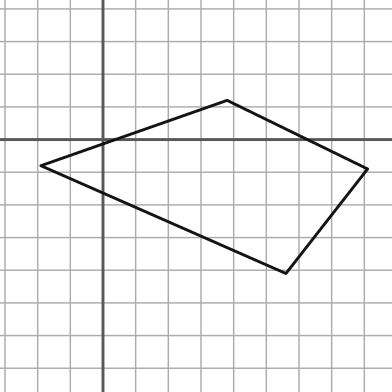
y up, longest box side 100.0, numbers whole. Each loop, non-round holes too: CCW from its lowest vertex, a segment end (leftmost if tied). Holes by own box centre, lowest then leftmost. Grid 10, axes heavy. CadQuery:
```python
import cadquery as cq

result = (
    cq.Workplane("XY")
    .moveTo(56.0, -41.0)
    .lineTo(81.0, -9.0)
    .lineTo(38.0, 12.0)
    .lineTo(-19.0, -8.0)
    .close()
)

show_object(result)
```